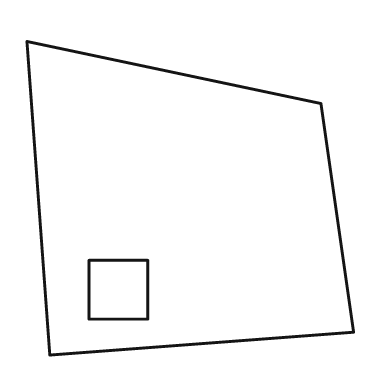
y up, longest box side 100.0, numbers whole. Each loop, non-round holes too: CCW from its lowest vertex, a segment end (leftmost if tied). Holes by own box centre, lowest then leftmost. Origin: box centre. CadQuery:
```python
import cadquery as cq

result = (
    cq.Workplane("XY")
    .moveTo(-43.0, -48.0)
    .lineTo(50.0, -41.0)
    .lineTo(40.0, 29.0)
    .lineTo(-50.0, 48.0)
    .close()
    .moveTo(-31.0, -37.0)
    .lineTo(-13.0, -37.0)
    .lineTo(-13.0, -19.0)
    .lineTo(-31.0, -19.0)
    .close()
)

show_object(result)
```